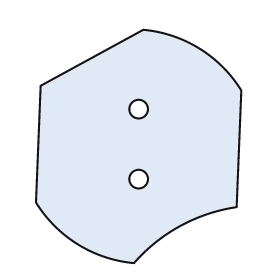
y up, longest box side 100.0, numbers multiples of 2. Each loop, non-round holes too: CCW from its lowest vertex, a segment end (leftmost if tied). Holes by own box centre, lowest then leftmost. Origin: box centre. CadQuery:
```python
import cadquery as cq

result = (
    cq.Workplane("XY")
    .moveTo(-2.0, -50.0)
    .threePointArc((18.0, -34.0), (42.0, -26.0))
    .lineTo(44.0, 24.0)
    .threePointArc((26.0, 42.0), (2.0, 50.0))
    .lineTo(-42.0, 26.0)
    .lineTo(-44.0, -24.0)
    .threePointArc((-26.0, -42.0), (-2.0, -50.0))
    .close()
    .moveTo(0.0, -14.0)
    .circle(4.0)
    .moveTo(0.0, 16.0)
    .circle(4.0)
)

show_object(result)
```